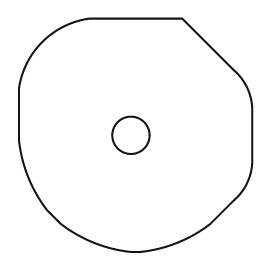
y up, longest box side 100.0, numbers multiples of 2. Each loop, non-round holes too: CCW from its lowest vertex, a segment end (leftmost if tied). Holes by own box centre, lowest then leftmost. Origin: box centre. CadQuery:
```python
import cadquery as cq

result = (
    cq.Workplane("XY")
    .moveTo(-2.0, -50.0)
    .lineTo(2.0, -50.0)
    .threePointArc((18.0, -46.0), (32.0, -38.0))
    .lineTo(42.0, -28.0)
    .threePointArc((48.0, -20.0), (50.0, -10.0))
    .lineTo(50.0, 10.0)
    .threePointArc((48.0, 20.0), (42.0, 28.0))
    .lineTo(20.0, 50.0)
    .lineTo(-20.0, 50.0)
    .threePointArc((-40.0, 40.0), (-50.0, 20.0))
    .lineTo(-50.0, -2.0)
    .threePointArc((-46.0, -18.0), (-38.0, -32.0))
    .lineTo(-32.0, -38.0)
    .threePointArc((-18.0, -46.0), (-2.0, -50.0))
    .close()
    .moveTo(-2.0, 0.0)
    .circle(8.0)
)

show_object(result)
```